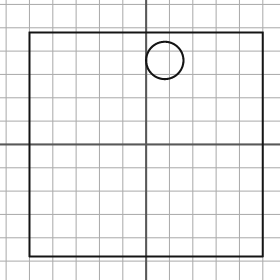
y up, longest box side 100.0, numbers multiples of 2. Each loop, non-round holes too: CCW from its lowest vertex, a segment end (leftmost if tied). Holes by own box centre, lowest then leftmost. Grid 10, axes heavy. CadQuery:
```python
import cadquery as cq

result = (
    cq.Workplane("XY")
    .moveTo(-50.0, -48.0)
    .lineTo(50.0, -48.0)
    .lineTo(50.0, 48.0)
    .lineTo(-50.0, 48.0)
    .close()
    .moveTo(8.0, 36.0)
    .circle(8.0)
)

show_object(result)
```